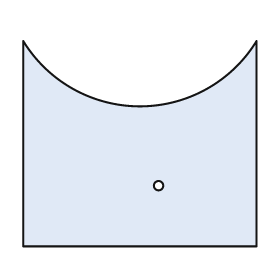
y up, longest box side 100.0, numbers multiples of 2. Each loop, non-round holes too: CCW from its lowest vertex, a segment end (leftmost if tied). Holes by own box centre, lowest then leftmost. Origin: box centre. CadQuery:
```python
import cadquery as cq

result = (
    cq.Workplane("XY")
    .moveTo(-50.0, -44.0)
    .lineTo(50.0, -44.0)
    .lineTo(50.0, 44.0)
    .threePointArc((0.0, 16.0), (-50.0, 44.0))
    .close()
    .moveTo(8.0, -18.0)
    .circle(2.0)
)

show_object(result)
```